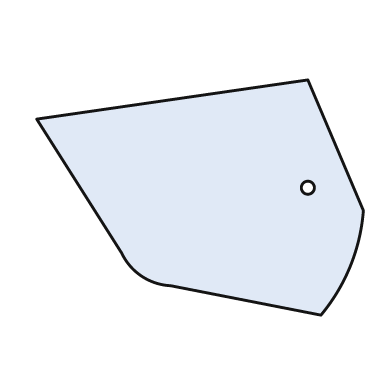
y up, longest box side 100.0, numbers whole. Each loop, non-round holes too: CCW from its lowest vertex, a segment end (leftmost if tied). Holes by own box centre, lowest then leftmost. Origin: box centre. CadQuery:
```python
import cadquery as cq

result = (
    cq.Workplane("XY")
    .moveTo(37.0, -36.0)
    .threePointArc((46.0, -21.0), (50.0, -4.0))
    .lineTo(33.0, 36.0)
    .lineTo(-50.0, 24.0)
    .lineTo(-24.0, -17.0)
    .threePointArc((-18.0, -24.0), (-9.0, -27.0))
    .close()
    .moveTo(33.0, 3.0)
    .circle(2.0)
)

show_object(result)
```